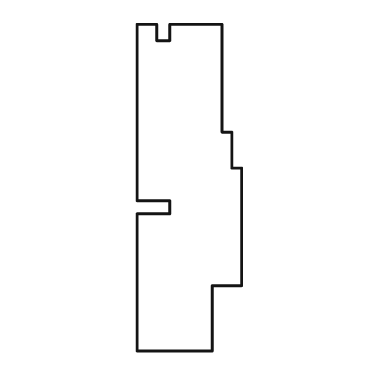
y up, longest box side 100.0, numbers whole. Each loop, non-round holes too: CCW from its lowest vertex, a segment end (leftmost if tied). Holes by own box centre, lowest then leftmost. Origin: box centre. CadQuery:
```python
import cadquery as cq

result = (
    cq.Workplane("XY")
    .moveTo(-16.0, -50.0)
    .lineTo(7.0, -50.0)
    .lineTo(7.0, -30.0)
    .lineTo(16.0, -30.0)
    .lineTo(16.0, 6.0)
    .lineTo(13.0, 6.0)
    .lineTo(13.0, 17.0)
    .lineTo(10.0, 17.0)
    .lineTo(10.0, 50.0)
    .lineTo(-6.0, 50.0)
    .lineTo(-6.0, 45.0)
    .lineTo(-10.0, 45.0)
    .lineTo(-10.0, 50.0)
    .lineTo(-16.0, 50.0)
    .lineTo(-16.0, -4.0)
    .lineTo(-6.0, -4.0)
    .lineTo(-6.0, -8.0)
    .lineTo(-16.0, -8.0)
    .close()
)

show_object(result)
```